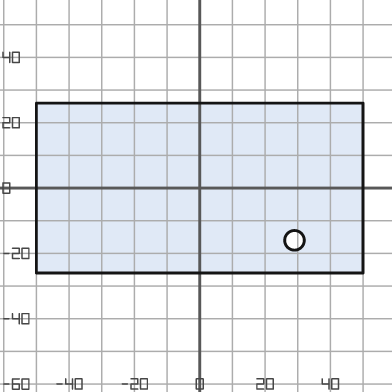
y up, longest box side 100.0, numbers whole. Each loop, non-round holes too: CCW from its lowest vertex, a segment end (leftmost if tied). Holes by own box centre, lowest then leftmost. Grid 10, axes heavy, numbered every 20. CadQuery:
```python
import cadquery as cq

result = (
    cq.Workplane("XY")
    .moveTo(-50.0, -26.0)
    .lineTo(50.0, -26.0)
    .lineTo(50.0, 26.0)
    .lineTo(-50.0, 26.0)
    .close()
    .moveTo(29.0, -16.0)
    .circle(3.0)
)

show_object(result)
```